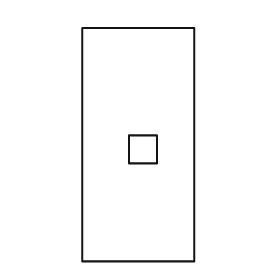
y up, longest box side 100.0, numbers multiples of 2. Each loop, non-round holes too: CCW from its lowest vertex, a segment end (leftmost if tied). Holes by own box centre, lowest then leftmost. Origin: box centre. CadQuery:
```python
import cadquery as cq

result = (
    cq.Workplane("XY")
    .moveTo(-24.0, -50.0)
    .lineTo(24.0, -50.0)
    .lineTo(24.0, 50.0)
    .lineTo(-24.0, 50.0)
    .close()
    .moveTo(-4.0, -8.0)
    .lineTo(8.0, -8.0)
    .lineTo(8.0, 4.0)
    .lineTo(-4.0, 4.0)
    .close()
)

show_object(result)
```